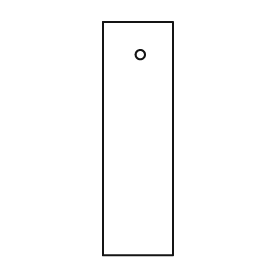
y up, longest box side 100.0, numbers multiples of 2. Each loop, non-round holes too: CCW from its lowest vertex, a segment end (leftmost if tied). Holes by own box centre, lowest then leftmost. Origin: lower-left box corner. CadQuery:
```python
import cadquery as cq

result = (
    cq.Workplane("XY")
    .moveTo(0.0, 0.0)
    .lineTo(30.0, 0.0)
    .lineTo(30.0, 100.0)
    .lineTo(0.0, 100.0)
    .close()
    .moveTo(16.0, 86.0)
    .circle(2.0)
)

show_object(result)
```